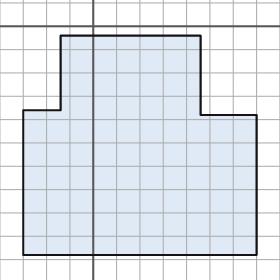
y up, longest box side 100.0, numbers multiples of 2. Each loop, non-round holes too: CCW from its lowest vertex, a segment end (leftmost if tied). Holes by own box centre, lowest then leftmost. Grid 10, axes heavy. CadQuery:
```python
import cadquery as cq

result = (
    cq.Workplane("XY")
    .moveTo(-30.0, -98.0)
    .lineTo(70.0, -98.0)
    .lineTo(70.0, -38.0)
    .lineTo(46.0, -38.0)
    .lineTo(46.0, -4.0)
    .lineTo(-14.0, -4.0)
    .lineTo(-14.0, -36.0)
    .lineTo(-30.0, -36.0)
    .close()
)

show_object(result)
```